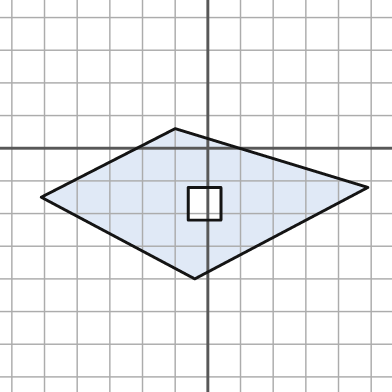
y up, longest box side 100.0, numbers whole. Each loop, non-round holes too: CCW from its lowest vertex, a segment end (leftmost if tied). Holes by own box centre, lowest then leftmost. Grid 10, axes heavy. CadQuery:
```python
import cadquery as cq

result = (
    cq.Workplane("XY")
    .moveTo(-4.0, -40.0)
    .lineTo(49.0, -12.0)
    .lineTo(-10.0, 6.0)
    .lineTo(-51.0, -15.0)
    .close()
    .moveTo(-6.0, -22.0)
    .lineTo(4.0, -22.0)
    .lineTo(4.0, -12.0)
    .lineTo(-6.0, -12.0)
    .close()
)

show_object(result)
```